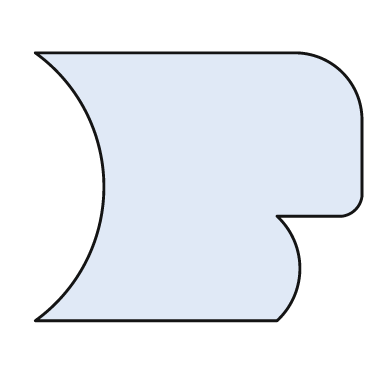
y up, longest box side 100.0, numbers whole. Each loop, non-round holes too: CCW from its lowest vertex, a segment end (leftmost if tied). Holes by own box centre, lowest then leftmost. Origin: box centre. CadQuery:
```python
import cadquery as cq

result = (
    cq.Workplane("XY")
    .moveTo(-50.0, -41.0)
    .lineTo(24.0, -41.0)
    .threePointArc((31.0, -25.0), (24.0, -9.0))
    .lineTo(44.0, -9.0)
    .threePointArc((48.0, -7.0), (50.0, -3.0))
    .lineTo(50.0, 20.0)
    .threePointArc((44.0, 35.0), (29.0, 41.0))
    .lineTo(-50.0, 41.0)
    .threePointArc((-29.0, 0.0), (-50.0, -41.0))
    .close()
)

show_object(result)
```